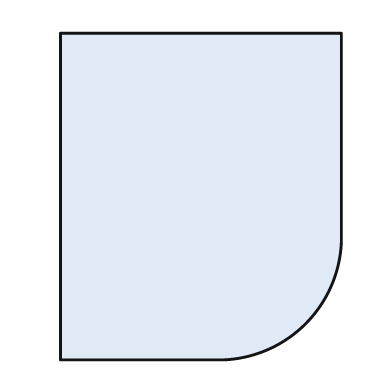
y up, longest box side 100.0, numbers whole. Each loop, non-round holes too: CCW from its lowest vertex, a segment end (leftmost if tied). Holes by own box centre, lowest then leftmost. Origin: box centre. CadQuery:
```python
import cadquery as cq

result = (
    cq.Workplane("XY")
    .moveTo(-43.0, -50.0)
    .lineTo(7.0, -50.0)
    .threePointArc((32.0, -39.0), (43.0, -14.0))
    .lineTo(43.0, 50.0)
    .lineTo(-43.0, 50.0)
    .close()
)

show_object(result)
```